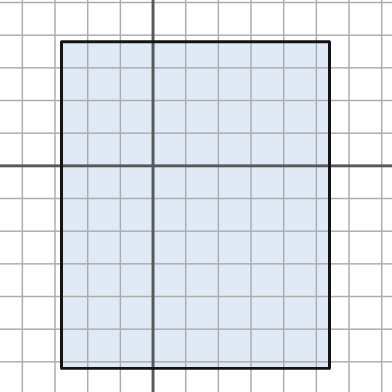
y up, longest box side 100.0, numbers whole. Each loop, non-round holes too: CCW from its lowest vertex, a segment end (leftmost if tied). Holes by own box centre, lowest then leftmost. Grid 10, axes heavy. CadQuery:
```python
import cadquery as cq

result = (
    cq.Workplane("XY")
    .moveTo(-28.0, -62.0)
    .lineTo(54.0, -62.0)
    .lineTo(54.0, 38.0)
    .lineTo(-28.0, 38.0)
    .close()
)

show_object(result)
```